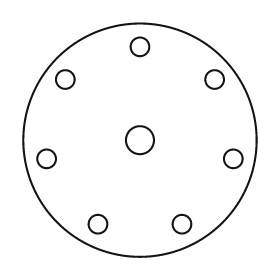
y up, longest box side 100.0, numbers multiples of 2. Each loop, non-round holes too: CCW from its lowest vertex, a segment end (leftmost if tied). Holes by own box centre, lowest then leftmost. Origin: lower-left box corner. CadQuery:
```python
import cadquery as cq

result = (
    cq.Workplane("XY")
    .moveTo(50.0, 50.0)
    .circle(50.0)
    .moveTo(32.0, 14.0)
    .circle(4.0)
    .moveTo(68.0, 14.0)
    .circle(4.0)
    .moveTo(10.0, 42.0)
    .circle(4.0)
    .moveTo(90.0, 42.0)
    .circle(4.0)
    .moveTo(50.0, 50.0)
    .circle(6.0)
    .moveTo(18.0, 76.0)
    .circle(4.0)
    .moveTo(82.0, 76.0)
    .circle(4.0)
    .moveTo(50.0, 90.0)
    .circle(4.0)
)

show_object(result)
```